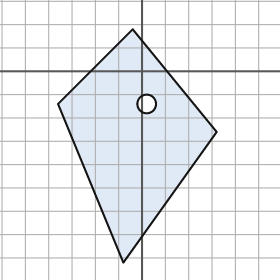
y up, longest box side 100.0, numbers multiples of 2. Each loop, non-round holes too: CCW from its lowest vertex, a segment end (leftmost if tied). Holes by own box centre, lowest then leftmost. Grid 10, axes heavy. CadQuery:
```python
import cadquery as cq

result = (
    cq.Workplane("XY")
    .moveTo(-8.0, -82.0)
    .lineTo(32.0, -26.0)
    .lineTo(-4.0, 18.0)
    .lineTo(-36.0, -14.0)
    .close()
    .moveTo(2.0, -14.0)
    .circle(4.0)
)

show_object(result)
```